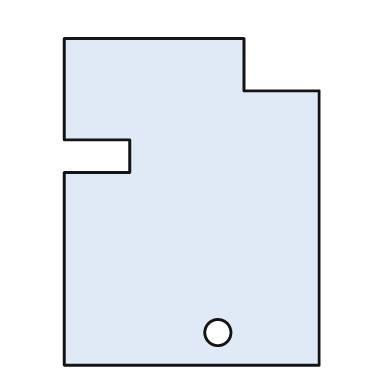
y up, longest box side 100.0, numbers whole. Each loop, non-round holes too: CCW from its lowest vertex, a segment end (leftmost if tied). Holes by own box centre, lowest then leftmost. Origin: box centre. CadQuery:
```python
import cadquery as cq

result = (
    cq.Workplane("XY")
    .moveTo(-39.0, -50.0)
    .lineTo(39.0, -50.0)
    .lineTo(39.0, 34.0)
    .lineTo(16.0, 34.0)
    .lineTo(16.0, 50.0)
    .lineTo(-39.0, 50.0)
    .lineTo(-39.0, 19.0)
    .lineTo(-19.0, 19.0)
    .lineTo(-19.0, 9.0)
    .lineTo(-39.0, 9.0)
    .close()
    .moveTo(8.0, -40.0)
    .circle(4.0)
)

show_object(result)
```